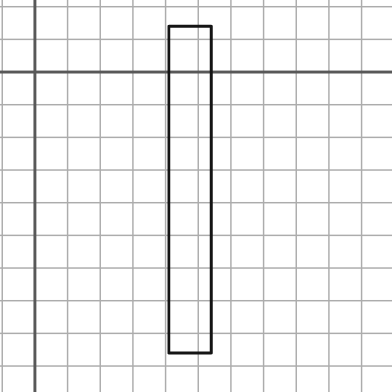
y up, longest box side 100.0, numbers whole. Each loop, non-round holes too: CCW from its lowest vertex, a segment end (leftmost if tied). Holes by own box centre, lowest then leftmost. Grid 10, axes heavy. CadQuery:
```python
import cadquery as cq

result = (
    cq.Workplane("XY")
    .moveTo(41.0, -86.0)
    .lineTo(54.0, -86.0)
    .lineTo(54.0, 14.0)
    .lineTo(41.0, 14.0)
    .close()
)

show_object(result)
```